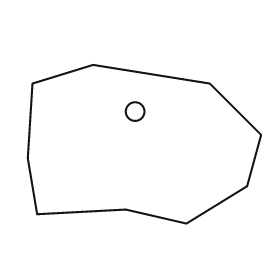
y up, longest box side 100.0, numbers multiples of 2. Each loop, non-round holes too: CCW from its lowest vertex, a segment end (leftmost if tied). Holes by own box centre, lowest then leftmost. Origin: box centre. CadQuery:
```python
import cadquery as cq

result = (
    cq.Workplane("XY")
    .moveTo(18.0, -34.0)
    .lineTo(44.0, -18.0)
    .lineTo(50.0, 4.0)
    .lineTo(28.0, 26.0)
    .lineTo(-22.0, 34.0)
    .lineTo(-48.0, 26.0)
    .lineTo(-50.0, -6.0)
    .lineTo(-46.0, -30.0)
    .lineTo(-8.0, -28.0)
    .close()
    .moveTo(-4.0, 14.0)
    .circle(4.0)
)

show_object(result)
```